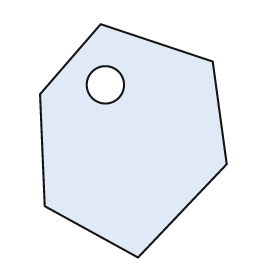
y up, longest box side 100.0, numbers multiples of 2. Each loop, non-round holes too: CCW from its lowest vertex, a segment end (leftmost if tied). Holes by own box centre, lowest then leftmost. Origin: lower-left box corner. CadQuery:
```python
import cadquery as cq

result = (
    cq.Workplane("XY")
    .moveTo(42.0, 0.0)
    .lineTo(80.0, 40.0)
    .lineTo(74.0, 84.0)
    .lineTo(26.0, 100.0)
    .lineTo(0.0, 70.0)
    .lineTo(2.0, 22.0)
    .close()
    .moveTo(28.0, 74.0)
    .circle(8.0)
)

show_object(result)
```